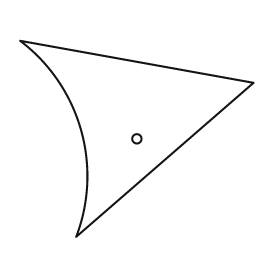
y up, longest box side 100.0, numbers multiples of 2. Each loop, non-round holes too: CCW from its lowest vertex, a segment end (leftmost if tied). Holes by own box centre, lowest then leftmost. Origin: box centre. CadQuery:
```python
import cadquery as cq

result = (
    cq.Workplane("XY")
    .moveTo(-26.0, -42.0)
    .lineTo(50.0, 24.0)
    .lineTo(-50.0, 42.0)
    .threePointArc((-24.0, 4.0), (-26.0, -42.0))
    .close()
    .moveTo(0.0, 0.0)
    .circle(2.0)
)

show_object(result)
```